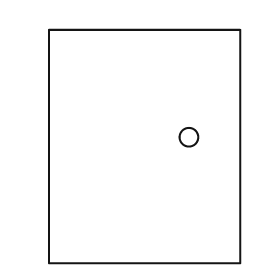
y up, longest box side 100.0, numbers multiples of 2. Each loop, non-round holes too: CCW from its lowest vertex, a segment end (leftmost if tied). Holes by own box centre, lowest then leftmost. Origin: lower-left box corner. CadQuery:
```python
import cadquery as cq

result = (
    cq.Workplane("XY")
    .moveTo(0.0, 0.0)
    .lineTo(82.0, 0.0)
    .lineTo(82.0, 100.0)
    .lineTo(0.0, 100.0)
    .close()
    .moveTo(60.0, 54.0)
    .circle(4.0)
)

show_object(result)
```